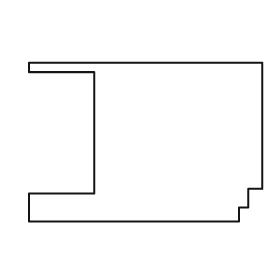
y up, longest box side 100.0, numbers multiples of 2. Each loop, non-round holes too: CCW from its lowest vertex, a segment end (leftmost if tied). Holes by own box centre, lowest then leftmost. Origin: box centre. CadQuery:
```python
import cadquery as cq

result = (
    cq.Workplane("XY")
    .moveTo(-50.0, -34.0)
    .lineTo(40.0, -34.0)
    .lineTo(40.0, -28.0)
    .lineTo(44.0, -28.0)
    .lineTo(44.0, -20.0)
    .lineTo(50.0, -20.0)
    .lineTo(50.0, 34.0)
    .lineTo(-50.0, 34.0)
    .lineTo(-50.0, 30.0)
    .lineTo(-22.0, 30.0)
    .lineTo(-22.0, -22.0)
    .lineTo(-50.0, -22.0)
    .close()
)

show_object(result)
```